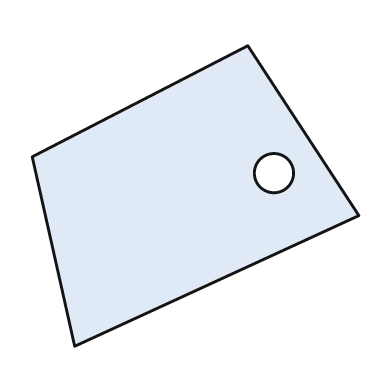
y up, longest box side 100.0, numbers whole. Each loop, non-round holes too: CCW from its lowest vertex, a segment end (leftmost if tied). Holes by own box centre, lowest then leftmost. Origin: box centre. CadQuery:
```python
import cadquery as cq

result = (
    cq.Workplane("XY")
    .moveTo(-37.0, -46.0)
    .lineTo(50.0, -6.0)
    .lineTo(16.0, 46.0)
    .lineTo(-50.0, 12.0)
    .close()
    .moveTo(24.0, 7.0)
    .circle(6.0)
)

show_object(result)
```